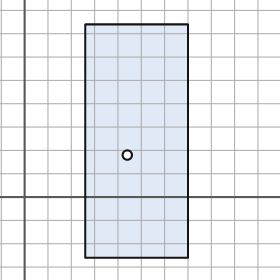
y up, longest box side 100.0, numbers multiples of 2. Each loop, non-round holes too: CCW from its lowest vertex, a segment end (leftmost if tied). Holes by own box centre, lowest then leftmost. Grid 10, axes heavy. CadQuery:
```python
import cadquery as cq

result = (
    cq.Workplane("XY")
    .moveTo(26.0, -26.0)
    .lineTo(70.0, -26.0)
    .lineTo(70.0, 74.0)
    .lineTo(26.0, 74.0)
    .close()
    .moveTo(44.0, 18.0)
    .circle(2.0)
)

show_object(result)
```